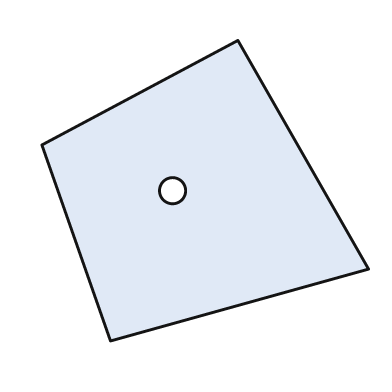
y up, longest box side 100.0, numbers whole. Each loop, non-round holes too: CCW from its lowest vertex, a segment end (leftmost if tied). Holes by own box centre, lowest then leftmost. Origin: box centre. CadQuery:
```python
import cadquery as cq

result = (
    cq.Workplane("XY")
    .moveTo(-29.0, -46.0)
    .lineTo(50.0, -24.0)
    .lineTo(10.0, 46.0)
    .lineTo(-50.0, 14.0)
    .close()
    .moveTo(-10.0, 0.0)
    .circle(4.0)
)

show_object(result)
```